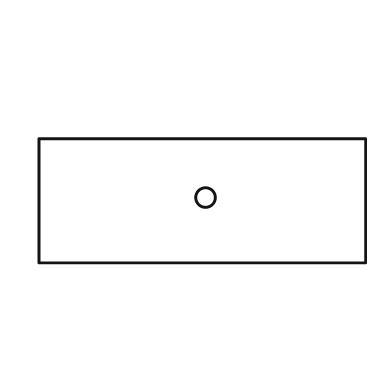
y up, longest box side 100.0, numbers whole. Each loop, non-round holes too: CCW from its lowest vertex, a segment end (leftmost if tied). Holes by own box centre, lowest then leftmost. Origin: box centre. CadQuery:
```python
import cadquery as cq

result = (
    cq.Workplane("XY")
    .moveTo(-50.0, -19.0)
    .lineTo(50.0, -19.0)
    .lineTo(50.0, 19.0)
    .lineTo(-50.0, 19.0)
    .close()
    .moveTo(1.0, 1.0)
    .circle(3.0)
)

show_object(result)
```